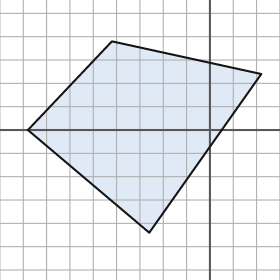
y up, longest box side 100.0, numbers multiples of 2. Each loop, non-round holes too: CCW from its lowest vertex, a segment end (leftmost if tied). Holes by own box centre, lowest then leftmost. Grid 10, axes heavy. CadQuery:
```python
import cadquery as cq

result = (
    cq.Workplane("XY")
    .moveTo(-26.0, -44.0)
    .lineTo(22.0, 24.0)
    .lineTo(-42.0, 38.0)
    .lineTo(-78.0, 0.0)
    .close()
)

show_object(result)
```